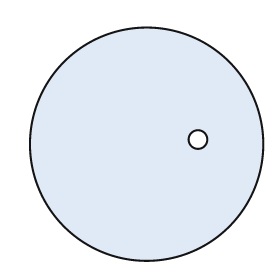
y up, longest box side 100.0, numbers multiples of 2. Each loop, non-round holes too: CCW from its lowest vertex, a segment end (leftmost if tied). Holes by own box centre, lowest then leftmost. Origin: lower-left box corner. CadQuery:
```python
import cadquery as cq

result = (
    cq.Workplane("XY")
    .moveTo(50.0, 50.0)
    .circle(50.0)
    .moveTo(72.0, 52.0)
    .circle(4.0)
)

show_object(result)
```